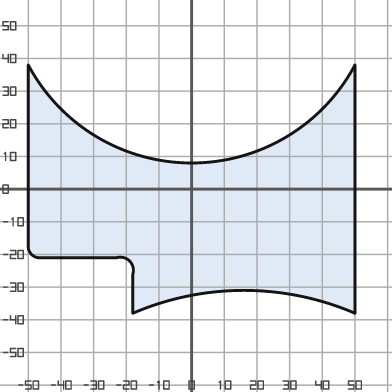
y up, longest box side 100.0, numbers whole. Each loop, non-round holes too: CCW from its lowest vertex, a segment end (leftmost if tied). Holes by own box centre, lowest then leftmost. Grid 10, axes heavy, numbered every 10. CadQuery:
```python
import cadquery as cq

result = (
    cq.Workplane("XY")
    .moveTo(-18.0, -38.0)
    .threePointArc((16.0, -31.0), (50.0, -38.0))
    .lineTo(50.0, 38.0)
    .threePointArc((0.0, 8.0), (-50.0, 38.0))
    .lineTo(-50.0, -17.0)
    .threePointArc((-49.0, -20.0), (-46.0, -21.0))
    .lineTo(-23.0, -21.0)
    .threePointArc((-19.0, -22.0), (-18.0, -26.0))
    .close()
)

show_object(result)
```